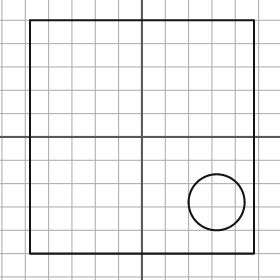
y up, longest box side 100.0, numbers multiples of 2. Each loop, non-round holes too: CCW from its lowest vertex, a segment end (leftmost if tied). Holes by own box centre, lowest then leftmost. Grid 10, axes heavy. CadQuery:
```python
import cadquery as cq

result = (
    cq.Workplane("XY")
    .moveTo(-48.0, -50.0)
    .lineTo(48.0, -50.0)
    .lineTo(48.0, 50.0)
    .lineTo(-48.0, 50.0)
    .close()
    .moveTo(32.0, -28.0)
    .circle(12.0)
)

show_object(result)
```